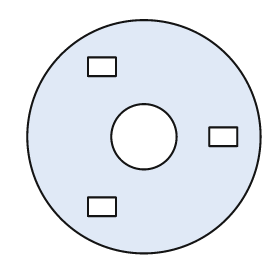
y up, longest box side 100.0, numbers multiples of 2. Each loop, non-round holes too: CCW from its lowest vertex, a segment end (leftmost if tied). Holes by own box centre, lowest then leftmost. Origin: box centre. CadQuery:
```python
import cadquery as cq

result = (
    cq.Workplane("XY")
    .moveTo(0.0, 0.0)
    .circle(50.0)
    .moveTo(-24.0, -34.0)
    .lineTo(-12.0, -34.0)
    .lineTo(-12.0, -26.0)
    .lineTo(-24.0, -26.0)
    .close()
    .moveTo(0.0, 0.0)
    .circle(14.0)
    .moveTo(28.0, -4.0)
    .lineTo(40.0, -4.0)
    .lineTo(40.0, 4.0)
    .lineTo(28.0, 4.0)
    .close()
    .moveTo(-24.0, 26.0)
    .lineTo(-12.0, 26.0)
    .lineTo(-12.0, 34.0)
    .lineTo(-24.0, 34.0)
    .close()
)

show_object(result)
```